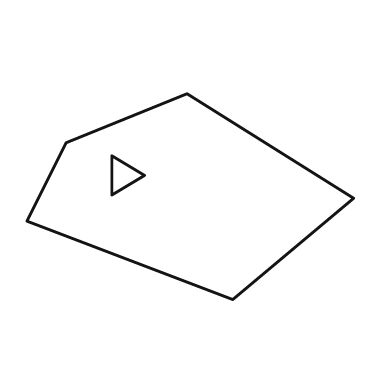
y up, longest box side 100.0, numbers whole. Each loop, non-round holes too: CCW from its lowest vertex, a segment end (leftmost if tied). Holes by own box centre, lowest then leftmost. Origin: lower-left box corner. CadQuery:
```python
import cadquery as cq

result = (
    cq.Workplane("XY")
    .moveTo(63.0, 0.0)
    .lineTo(100.0, 31.0)
    .lineTo(49.0, 63.0)
    .lineTo(12.0, 48.0)
    .lineTo(0.0, 24.0)
    .close()
    .moveTo(26.0, 32.0)
    .lineTo(36.0, 38.0)
    .lineTo(26.0, 44.0)
    .close()
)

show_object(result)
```